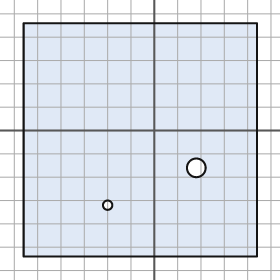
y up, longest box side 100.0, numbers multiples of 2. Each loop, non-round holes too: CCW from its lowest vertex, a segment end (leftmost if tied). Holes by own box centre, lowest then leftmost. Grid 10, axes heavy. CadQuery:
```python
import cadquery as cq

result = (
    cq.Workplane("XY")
    .moveTo(-56.0, -54.0)
    .lineTo(44.0, -54.0)
    .lineTo(44.0, 46.0)
    .lineTo(-56.0, 46.0)
    .close()
    .moveTo(-20.0, -32.0)
    .circle(2.0)
    .moveTo(18.0, -16.0)
    .circle(4.0)
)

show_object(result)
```